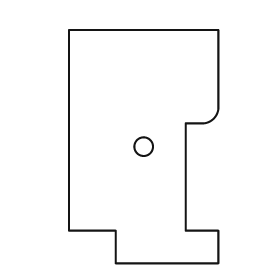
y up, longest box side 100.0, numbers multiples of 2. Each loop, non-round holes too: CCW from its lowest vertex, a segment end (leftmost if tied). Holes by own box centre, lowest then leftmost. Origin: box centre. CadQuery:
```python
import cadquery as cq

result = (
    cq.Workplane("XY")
    .moveTo(-12.0, -50.0)
    .lineTo(32.0, -50.0)
    .lineTo(32.0, -36.0)
    .lineTo(18.0, -36.0)
    .lineTo(18.0, 10.0)
    .lineTo(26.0, 10.0)
    .threePointArc((30.0, 12.0), (32.0, 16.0))
    .lineTo(32.0, 50.0)
    .lineTo(-32.0, 50.0)
    .lineTo(-32.0, -36.0)
    .lineTo(-12.0, -36.0)
    .close()
    .moveTo(0.0, 0.0)
    .circle(4.0)
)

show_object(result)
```